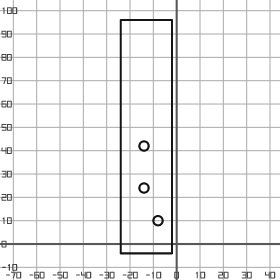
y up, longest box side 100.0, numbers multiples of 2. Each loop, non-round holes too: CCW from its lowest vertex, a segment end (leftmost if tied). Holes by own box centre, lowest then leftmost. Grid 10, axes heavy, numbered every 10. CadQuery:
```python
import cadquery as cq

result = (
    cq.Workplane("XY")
    .moveTo(-24.0, -4.0)
    .lineTo(-2.0, -4.0)
    .lineTo(-2.0, 96.0)
    .lineTo(-24.0, 96.0)
    .close()
    .moveTo(-8.0, 10.0)
    .circle(2.0)
    .moveTo(-14.0, 24.0)
    .circle(2.0)
    .moveTo(-14.0, 42.0)
    .circle(2.0)
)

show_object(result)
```